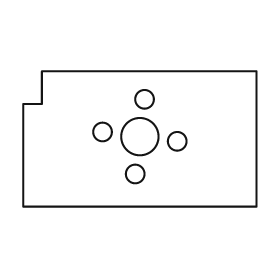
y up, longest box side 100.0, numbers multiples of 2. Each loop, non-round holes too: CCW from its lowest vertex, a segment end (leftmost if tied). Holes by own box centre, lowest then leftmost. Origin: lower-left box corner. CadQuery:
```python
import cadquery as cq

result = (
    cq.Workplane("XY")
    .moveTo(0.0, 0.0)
    .lineTo(100.0, 0.0)
    .lineTo(100.0, 58.0)
    .lineTo(8.0, 58.0)
    .lineTo(8.0, 44.0)
    .lineTo(0.0, 44.0)
    .close()
    .moveTo(48.0, 14.0)
    .circle(4.0)
    .moveTo(66.0, 28.0)
    .circle(4.0)
    .moveTo(50.0, 30.0)
    .circle(8.0)
    .moveTo(34.0, 32.0)
    .circle(4.0)
    .moveTo(52.0, 46.0)
    .circle(4.0)
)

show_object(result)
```